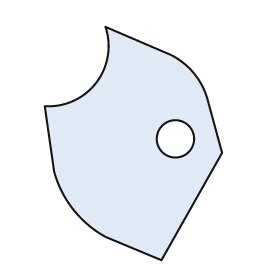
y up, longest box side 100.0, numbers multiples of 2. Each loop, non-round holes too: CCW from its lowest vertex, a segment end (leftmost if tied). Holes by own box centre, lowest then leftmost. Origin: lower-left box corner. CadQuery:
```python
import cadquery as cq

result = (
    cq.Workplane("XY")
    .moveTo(50.0, 0.0)
    .lineTo(76.0, 46.0)
    .lineTo(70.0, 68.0)
    .threePointArc((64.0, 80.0), (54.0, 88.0))
    .lineTo(26.0, 100.0)
    .threePointArc((22.0, 76.0), (0.0, 66.0))
    .lineTo(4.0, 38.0)
    .threePointArc((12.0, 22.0), (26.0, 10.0))
    .close()
    .moveTo(56.0, 52.0)
    .circle(8.0)
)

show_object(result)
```